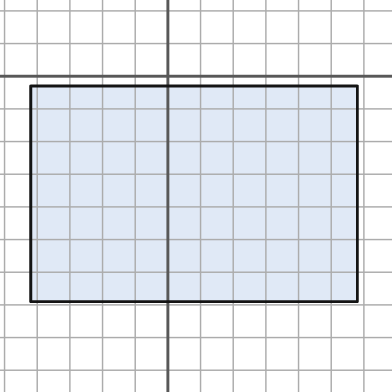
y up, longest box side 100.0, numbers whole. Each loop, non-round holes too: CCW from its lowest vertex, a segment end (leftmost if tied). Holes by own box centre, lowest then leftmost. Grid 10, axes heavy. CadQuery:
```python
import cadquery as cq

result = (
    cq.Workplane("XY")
    .moveTo(-42.0, -69.0)
    .lineTo(58.0, -69.0)
    .lineTo(58.0, -3.0)
    .lineTo(-42.0, -3.0)
    .close()
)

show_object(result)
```